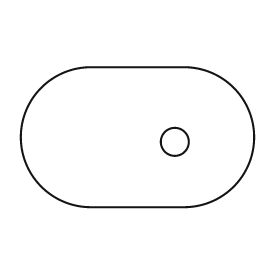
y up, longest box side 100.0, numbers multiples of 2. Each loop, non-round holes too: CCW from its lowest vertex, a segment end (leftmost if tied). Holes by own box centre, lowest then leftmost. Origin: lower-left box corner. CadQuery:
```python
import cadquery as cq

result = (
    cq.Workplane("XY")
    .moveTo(30.0, 0.0)
    .lineTo(70.0, 0.0)
    .threePointArc((100.0, 30.0), (70.0, 60.0))
    .lineTo(30.0, 60.0)
    .threePointArc((0.0, 30.0), (30.0, 0.0))
    .close()
    .moveTo(66.0, 28.0)
    .circle(6.0)
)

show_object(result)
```